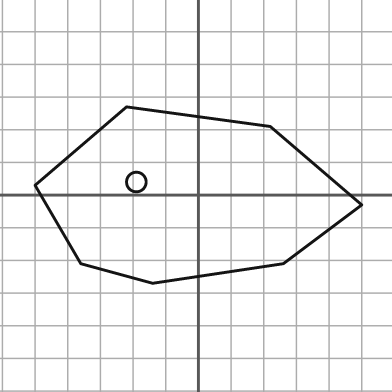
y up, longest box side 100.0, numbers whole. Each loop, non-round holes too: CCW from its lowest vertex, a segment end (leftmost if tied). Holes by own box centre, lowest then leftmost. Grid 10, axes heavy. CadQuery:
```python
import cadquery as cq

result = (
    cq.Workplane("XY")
    .moveTo(-14.0, -27.0)
    .lineTo(26.0, -21.0)
    .lineTo(50.0, -3.0)
    .lineTo(22.0, 21.0)
    .lineTo(-22.0, 27.0)
    .lineTo(-50.0, 3.0)
    .lineTo(-36.0, -21.0)
    .close()
    .moveTo(-19.0, 4.0)
    .circle(3.0)
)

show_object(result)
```